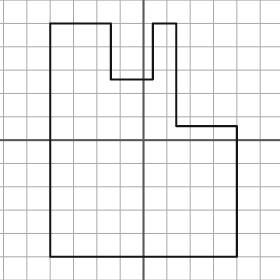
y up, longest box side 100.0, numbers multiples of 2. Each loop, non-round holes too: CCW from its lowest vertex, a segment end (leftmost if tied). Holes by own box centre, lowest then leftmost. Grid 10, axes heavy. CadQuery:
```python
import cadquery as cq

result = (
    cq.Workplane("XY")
    .moveTo(-40.0, -50.0)
    .lineTo(40.0, -50.0)
    .lineTo(40.0, 6.0)
    .lineTo(14.0, 6.0)
    .lineTo(14.0, 50.0)
    .lineTo(4.0, 50.0)
    .lineTo(4.0, 26.0)
    .lineTo(-14.0, 26.0)
    .lineTo(-14.0, 50.0)
    .lineTo(-40.0, 50.0)
    .close()
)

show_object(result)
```